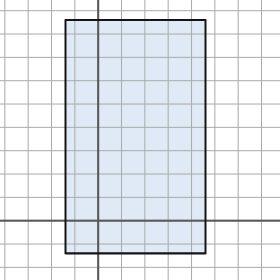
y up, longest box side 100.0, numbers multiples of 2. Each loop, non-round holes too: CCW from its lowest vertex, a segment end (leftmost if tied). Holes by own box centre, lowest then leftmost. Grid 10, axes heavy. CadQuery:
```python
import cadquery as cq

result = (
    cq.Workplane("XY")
    .moveTo(-14.0, -14.0)
    .lineTo(46.0, -14.0)
    .lineTo(46.0, 86.0)
    .lineTo(-14.0, 86.0)
    .close()
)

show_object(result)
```